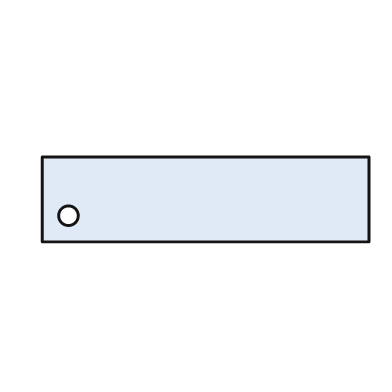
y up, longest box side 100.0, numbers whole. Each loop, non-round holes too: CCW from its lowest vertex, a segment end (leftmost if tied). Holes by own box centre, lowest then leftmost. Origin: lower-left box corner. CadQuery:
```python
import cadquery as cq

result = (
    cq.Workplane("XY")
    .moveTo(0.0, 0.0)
    .lineTo(100.0, 0.0)
    .lineTo(100.0, 26.0)
    .lineTo(0.0, 26.0)
    .close()
    .moveTo(8.0, 8.0)
    .circle(3.0)
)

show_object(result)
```